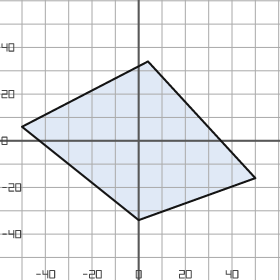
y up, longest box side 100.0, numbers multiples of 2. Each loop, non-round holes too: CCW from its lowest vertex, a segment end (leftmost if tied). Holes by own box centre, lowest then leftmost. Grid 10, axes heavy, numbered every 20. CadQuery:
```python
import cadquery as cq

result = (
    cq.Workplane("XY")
    .moveTo(0.0, -34.0)
    .lineTo(50.0, -16.0)
    .lineTo(4.0, 34.0)
    .lineTo(-50.0, 6.0)
    .close()
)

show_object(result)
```